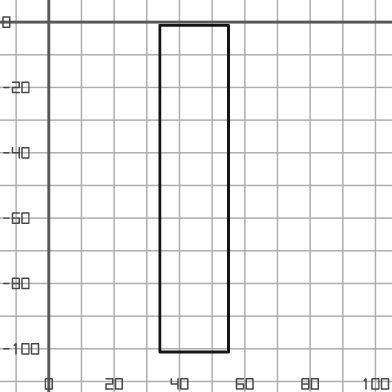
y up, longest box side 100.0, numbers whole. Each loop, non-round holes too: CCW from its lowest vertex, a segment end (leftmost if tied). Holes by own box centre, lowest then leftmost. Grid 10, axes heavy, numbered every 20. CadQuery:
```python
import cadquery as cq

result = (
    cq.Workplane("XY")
    .moveTo(34.0, -101.0)
    .lineTo(55.0, -101.0)
    .lineTo(55.0, -1.0)
    .lineTo(34.0, -1.0)
    .close()
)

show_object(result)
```